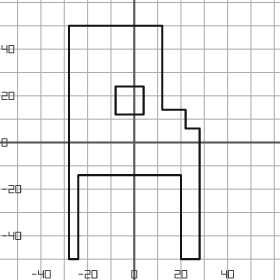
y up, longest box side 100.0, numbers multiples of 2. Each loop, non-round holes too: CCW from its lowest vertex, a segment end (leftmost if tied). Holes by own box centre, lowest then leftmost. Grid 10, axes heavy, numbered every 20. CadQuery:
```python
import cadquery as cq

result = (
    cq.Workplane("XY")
    .moveTo(-28.0, -50.0)
    .lineTo(-24.0, -50.0)
    .lineTo(-24.0, -14.0)
    .lineTo(20.0, -14.0)
    .lineTo(20.0, -50.0)
    .lineTo(28.0, -50.0)
    .lineTo(28.0, 6.0)
    .lineTo(22.0, 6.0)
    .lineTo(22.0, 14.0)
    .lineTo(12.0, 14.0)
    .lineTo(12.0, 50.0)
    .lineTo(-28.0, 50.0)
    .close()
    .moveTo(-8.0, 12.0)
    .lineTo(4.0, 12.0)
    .lineTo(4.0, 24.0)
    .lineTo(-8.0, 24.0)
    .close()
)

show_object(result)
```